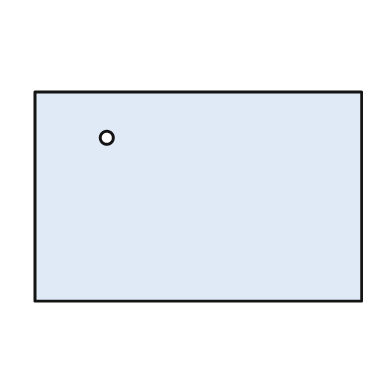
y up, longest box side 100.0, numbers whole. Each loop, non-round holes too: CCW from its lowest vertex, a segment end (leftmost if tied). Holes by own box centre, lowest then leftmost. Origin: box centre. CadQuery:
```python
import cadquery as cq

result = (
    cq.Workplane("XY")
    .moveTo(-50.0, -32.0)
    .lineTo(50.0, -32.0)
    .lineTo(50.0, 32.0)
    .lineTo(-50.0, 32.0)
    .close()
    .moveTo(-28.0, 18.0)
    .circle(2.0)
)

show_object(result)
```